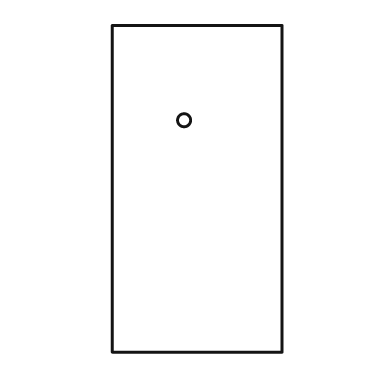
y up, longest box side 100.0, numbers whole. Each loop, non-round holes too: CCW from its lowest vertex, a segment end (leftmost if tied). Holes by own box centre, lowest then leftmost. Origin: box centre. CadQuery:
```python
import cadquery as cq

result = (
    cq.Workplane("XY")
    .moveTo(-26.0, -50.0)
    .lineTo(26.0, -50.0)
    .lineTo(26.0, 50.0)
    .lineTo(-26.0, 50.0)
    .close()
    .moveTo(-4.0, 21.0)
    .circle(2.0)
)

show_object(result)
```